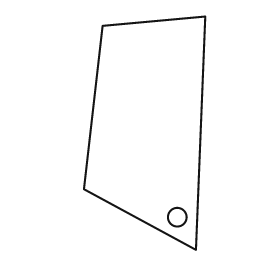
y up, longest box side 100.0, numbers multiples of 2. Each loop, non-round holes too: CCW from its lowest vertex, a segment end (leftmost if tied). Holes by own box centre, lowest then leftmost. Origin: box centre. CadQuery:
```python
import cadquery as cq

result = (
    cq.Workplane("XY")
    .moveTo(22.0, -50.0)
    .lineTo(26.0, 50.0)
    .lineTo(-18.0, 46.0)
    .lineTo(-26.0, -24.0)
    .close()
    .moveTo(14.0, -36.0)
    .circle(4.0)
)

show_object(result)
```